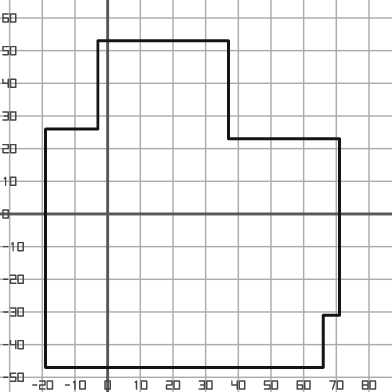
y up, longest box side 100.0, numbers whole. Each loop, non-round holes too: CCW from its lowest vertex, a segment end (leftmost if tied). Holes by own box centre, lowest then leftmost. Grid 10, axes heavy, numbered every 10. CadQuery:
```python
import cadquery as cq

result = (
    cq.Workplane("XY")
    .moveTo(-19.0, -47.0)
    .lineTo(66.0, -47.0)
    .lineTo(66.0, -31.0)
    .lineTo(71.0, -31.0)
    .lineTo(71.0, 23.0)
    .lineTo(37.0, 23.0)
    .lineTo(37.0, 53.0)
    .lineTo(-3.0, 53.0)
    .lineTo(-3.0, 26.0)
    .lineTo(-19.0, 26.0)
    .close()
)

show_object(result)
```